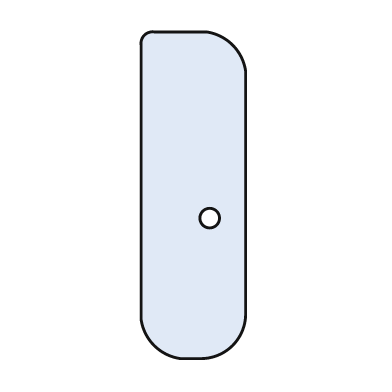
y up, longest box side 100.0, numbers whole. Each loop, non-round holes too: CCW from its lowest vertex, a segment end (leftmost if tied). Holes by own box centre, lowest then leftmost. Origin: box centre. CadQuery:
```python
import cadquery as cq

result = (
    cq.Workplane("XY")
    .moveTo(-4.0, -50.0)
    .lineTo(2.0, -50.0)
    .threePointArc((12.0, -46.0), (16.0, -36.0))
    .lineTo(16.0, 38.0)
    .threePointArc((12.0, 46.0), (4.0, 50.0))
    .lineTo(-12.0, 50.0)
    .threePointArc((-15.0, 49.0), (-16.0, 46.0))
    .lineTo(-16.0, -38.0)
    .threePointArc((-12.0, -46.0), (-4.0, -50.0))
    .close()
    .moveTo(5.0, -7.0)
    .circle(3.0)
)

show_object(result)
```